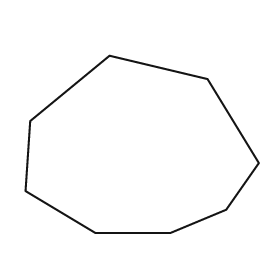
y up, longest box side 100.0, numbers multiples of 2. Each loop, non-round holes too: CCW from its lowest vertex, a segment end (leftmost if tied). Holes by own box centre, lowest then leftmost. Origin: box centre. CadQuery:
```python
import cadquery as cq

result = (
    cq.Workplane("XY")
    .moveTo(-20.0, -38.0)
    .lineTo(12.0, -38.0)
    .lineTo(36.0, -28.0)
    .lineTo(50.0, -8.0)
    .lineTo(28.0, 28.0)
    .lineTo(-14.0, 38.0)
    .lineTo(-48.0, 10.0)
    .lineTo(-50.0, -20.0)
    .close()
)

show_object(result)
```